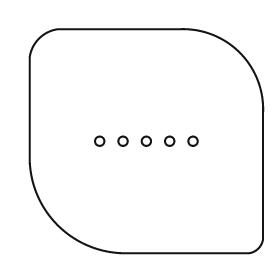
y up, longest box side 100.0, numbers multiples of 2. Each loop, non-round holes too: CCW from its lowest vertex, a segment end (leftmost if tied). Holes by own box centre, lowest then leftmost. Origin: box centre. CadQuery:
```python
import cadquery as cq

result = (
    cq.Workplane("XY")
    .moveTo(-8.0, -48.0)
    .lineTo(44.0, -48.0)
    .threePointArc((48.0, -46.0), (50.0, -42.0))
    .lineTo(50.0, 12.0)
    .threePointArc((40.0, 38.0), (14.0, 48.0))
    .lineTo(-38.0, 48.0)
    .threePointArc((-46.0, 44.0), (-50.0, 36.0))
    .lineTo(-50.0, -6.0)
    .threePointArc((-38.0, -36.0), (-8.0, -48.0))
    .close()
    .moveTo(-20.0, 0.0)
    .circle(2.0)
    .moveTo(-10.0, 0.0)
    .circle(2.0)
    .moveTo(0.0, 0.0)
    .circle(2.0)
    .moveTo(10.0, 0.0)
    .circle(2.0)
    .moveTo(20.0, 0.0)
    .circle(2.0)
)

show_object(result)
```